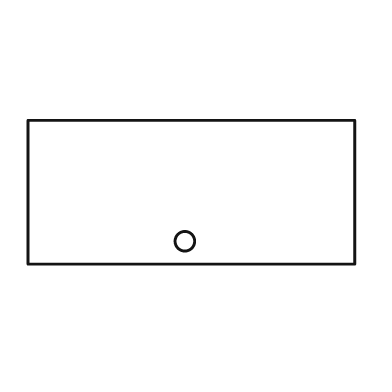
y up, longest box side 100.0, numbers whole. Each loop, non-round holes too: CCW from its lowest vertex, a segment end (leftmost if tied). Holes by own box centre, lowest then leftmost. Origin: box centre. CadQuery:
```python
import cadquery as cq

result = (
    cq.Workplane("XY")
    .moveTo(-50.0, -22.0)
    .lineTo(50.0, -22.0)
    .lineTo(50.0, 22.0)
    .lineTo(-50.0, 22.0)
    .close()
    .moveTo(-2.0, -15.0)
    .circle(3.0)
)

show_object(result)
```